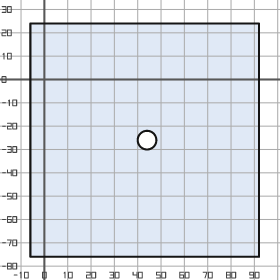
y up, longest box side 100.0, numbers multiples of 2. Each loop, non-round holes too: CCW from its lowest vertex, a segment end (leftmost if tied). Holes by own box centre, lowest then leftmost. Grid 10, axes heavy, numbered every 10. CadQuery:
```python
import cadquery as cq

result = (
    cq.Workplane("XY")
    .moveTo(-6.0, -76.0)
    .lineTo(92.0, -76.0)
    .lineTo(92.0, 24.0)
    .lineTo(-6.0, 24.0)
    .close()
    .moveTo(44.0, -26.0)
    .circle(4.0)
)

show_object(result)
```